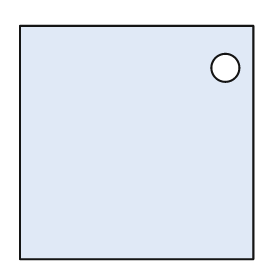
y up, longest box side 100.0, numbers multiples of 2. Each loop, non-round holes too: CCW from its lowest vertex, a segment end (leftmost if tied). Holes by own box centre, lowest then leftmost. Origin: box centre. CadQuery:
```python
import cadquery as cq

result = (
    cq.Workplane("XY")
    .moveTo(-50.0, -50.0)
    .lineTo(50.0, -50.0)
    .lineTo(50.0, 50.0)
    .lineTo(-50.0, 50.0)
    .close()
    .moveTo(38.0, 32.0)
    .circle(6.0)
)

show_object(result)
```